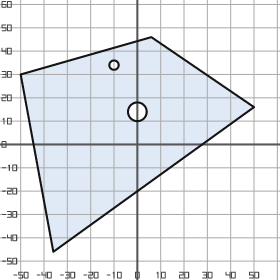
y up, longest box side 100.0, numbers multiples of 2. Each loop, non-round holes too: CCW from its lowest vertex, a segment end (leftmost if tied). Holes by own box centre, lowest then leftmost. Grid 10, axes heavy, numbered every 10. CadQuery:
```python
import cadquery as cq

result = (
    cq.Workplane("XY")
    .moveTo(-36.0, -46.0)
    .lineTo(50.0, 16.0)
    .lineTo(6.0, 46.0)
    .lineTo(-50.0, 30.0)
    .close()
    .moveTo(0.0, 14.0)
    .circle(4.0)
    .moveTo(-10.0, 34.0)
    .circle(2.0)
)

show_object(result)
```